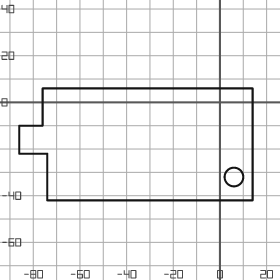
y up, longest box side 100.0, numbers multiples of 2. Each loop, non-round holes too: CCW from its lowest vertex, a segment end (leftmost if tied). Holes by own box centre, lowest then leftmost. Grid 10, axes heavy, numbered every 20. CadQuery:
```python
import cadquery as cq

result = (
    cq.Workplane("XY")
    .moveTo(-74.0, -42.0)
    .lineTo(14.0, -42.0)
    .lineTo(14.0, 6.0)
    .lineTo(-76.0, 6.0)
    .lineTo(-76.0, -10.0)
    .lineTo(-86.0, -10.0)
    .lineTo(-86.0, -22.0)
    .lineTo(-74.0, -22.0)
    .close()
    .moveTo(6.0, -32.0)
    .circle(4.0)
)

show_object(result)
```